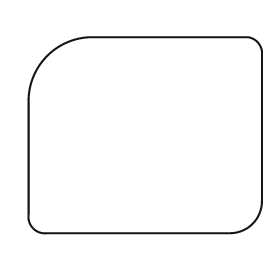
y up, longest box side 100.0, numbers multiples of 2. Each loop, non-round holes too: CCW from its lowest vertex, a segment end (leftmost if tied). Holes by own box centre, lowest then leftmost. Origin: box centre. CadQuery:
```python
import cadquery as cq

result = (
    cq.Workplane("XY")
    .moveTo(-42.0, -42.0)
    .lineTo(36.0, -42.0)
    .threePointArc((46.0, -38.0), (50.0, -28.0))
    .lineTo(50.0, 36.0)
    .threePointArc((48.0, 40.0), (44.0, 42.0))
    .lineTo(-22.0, 42.0)
    .threePointArc((-42.0, 34.0), (-50.0, 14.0))
    .lineTo(-50.0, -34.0)
    .threePointArc((-48.0, -40.0), (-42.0, -42.0))
    .close()
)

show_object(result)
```